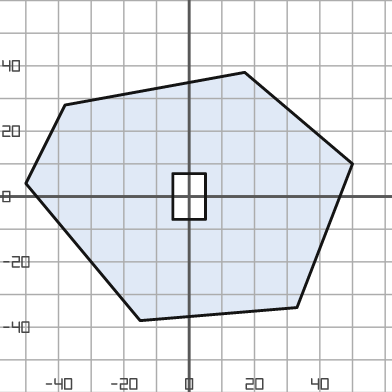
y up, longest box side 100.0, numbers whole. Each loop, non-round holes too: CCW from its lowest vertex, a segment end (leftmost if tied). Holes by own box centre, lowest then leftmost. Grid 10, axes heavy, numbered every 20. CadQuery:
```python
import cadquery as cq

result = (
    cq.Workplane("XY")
    .moveTo(-15.0, -38.0)
    .lineTo(33.0, -34.0)
    .lineTo(50.0, 10.0)
    .lineTo(17.0, 38.0)
    .lineTo(-38.0, 28.0)
    .lineTo(-50.0, 4.0)
    .close()
    .moveTo(-5.0, -7.0)
    .lineTo(5.0, -7.0)
    .lineTo(5.0, 7.0)
    .lineTo(-5.0, 7.0)
    .close()
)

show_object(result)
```